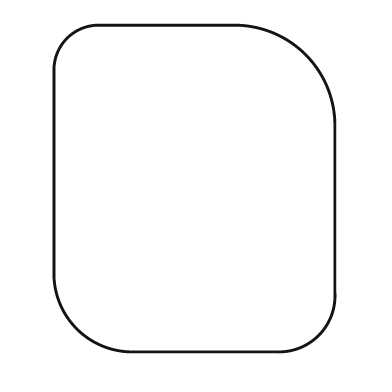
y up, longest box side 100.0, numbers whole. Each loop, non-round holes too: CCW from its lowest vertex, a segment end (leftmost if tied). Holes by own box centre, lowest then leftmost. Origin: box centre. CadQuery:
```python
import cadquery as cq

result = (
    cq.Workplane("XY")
    .moveTo(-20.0, -50.0)
    .lineTo(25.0, -50.0)
    .threePointArc((38.0, -45.0), (43.0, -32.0))
    .lineTo(43.0, 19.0)
    .threePointArc((34.0, 41.0), (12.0, 50.0))
    .lineTo(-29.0, 50.0)
    .threePointArc((-39.0, 46.0), (-43.0, 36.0))
    .lineTo(-43.0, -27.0)
    .threePointArc((-36.0, -43.0), (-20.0, -50.0))
    .close()
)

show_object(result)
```